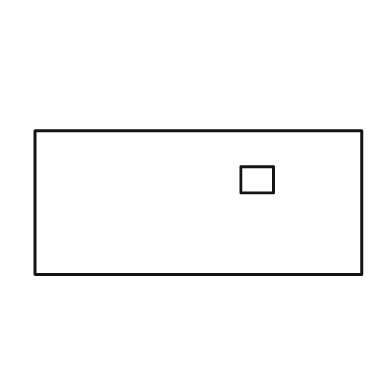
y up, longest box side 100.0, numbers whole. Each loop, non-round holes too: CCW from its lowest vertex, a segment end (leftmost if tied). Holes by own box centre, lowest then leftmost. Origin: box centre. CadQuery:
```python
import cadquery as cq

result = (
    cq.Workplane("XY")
    .moveTo(-50.0, -22.0)
    .lineTo(50.0, -22.0)
    .lineTo(50.0, 22.0)
    .lineTo(-50.0, 22.0)
    .close()
    .moveTo(13.0, 3.0)
    .lineTo(23.0, 3.0)
    .lineTo(23.0, 11.0)
    .lineTo(13.0, 11.0)
    .close()
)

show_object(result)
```